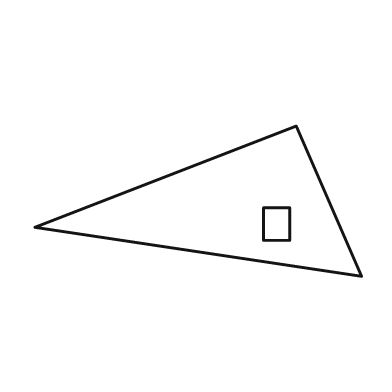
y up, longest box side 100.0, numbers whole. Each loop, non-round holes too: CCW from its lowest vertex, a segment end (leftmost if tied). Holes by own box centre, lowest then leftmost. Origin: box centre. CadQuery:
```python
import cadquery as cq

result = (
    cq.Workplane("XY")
    .moveTo(50.0, -23.0)
    .lineTo(30.0, 23.0)
    .lineTo(-50.0, -8.0)
    .close()
    .moveTo(20.0, -12.0)
    .lineTo(28.0, -12.0)
    .lineTo(28.0, -2.0)
    .lineTo(20.0, -2.0)
    .close()
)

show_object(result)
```